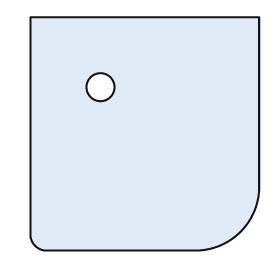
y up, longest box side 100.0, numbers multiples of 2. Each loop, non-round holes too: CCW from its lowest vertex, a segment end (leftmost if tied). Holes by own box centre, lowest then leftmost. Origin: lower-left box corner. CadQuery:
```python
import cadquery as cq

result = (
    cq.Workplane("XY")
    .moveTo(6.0, 0.0)
    .lineTo(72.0, 0.0)
    .threePointArc((90.0, 8.0), (98.0, 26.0))
    .lineTo(98.0, 100.0)
    .lineTo(0.0, 100.0)
    .lineTo(0.0, 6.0)
    .threePointArc((2.0, 2.0), (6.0, 0.0))
    .close()
    .moveTo(30.0, 70.0)
    .circle(6.0)
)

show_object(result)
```